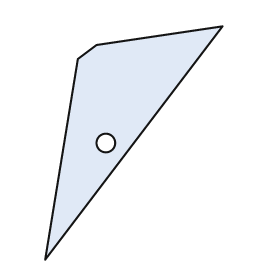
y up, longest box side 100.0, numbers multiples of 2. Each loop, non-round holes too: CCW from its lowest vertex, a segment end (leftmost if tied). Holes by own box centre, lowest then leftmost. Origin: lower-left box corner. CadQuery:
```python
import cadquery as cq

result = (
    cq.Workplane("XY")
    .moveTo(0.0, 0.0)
    .lineTo(76.0, 100.0)
    .lineTo(22.0, 92.0)
    .lineTo(14.0, 86.0)
    .close()
    .moveTo(26.0, 50.0)
    .circle(4.0)
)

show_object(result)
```